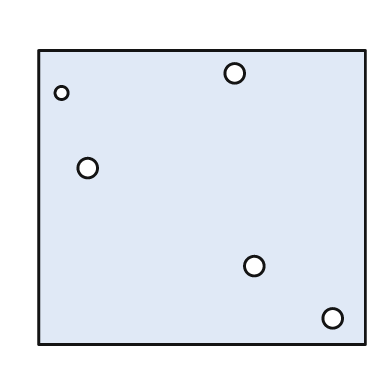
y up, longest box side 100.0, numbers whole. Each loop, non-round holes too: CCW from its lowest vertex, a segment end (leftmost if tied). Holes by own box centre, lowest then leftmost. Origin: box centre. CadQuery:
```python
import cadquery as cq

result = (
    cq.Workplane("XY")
    .moveTo(-50.0, -45.0)
    .lineTo(50.0, -45.0)
    .lineTo(50.0, 45.0)
    .lineTo(-50.0, 45.0)
    .close()
    .moveTo(40.0, -37.0)
    .circle(3.0)
    .moveTo(16.0, -21.0)
    .circle(3.0)
    .moveTo(-35.0, 9.0)
    .circle(3.0)
    .moveTo(-43.0, 32.0)
    .circle(2.0)
    .moveTo(10.0, 38.0)
    .circle(3.0)
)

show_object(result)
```